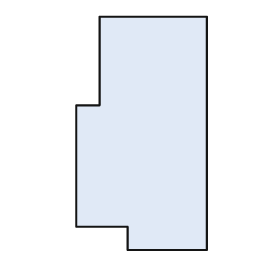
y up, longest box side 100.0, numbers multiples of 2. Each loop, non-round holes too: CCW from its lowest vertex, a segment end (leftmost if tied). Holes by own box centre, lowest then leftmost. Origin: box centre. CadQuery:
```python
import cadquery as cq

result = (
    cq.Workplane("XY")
    .moveTo(-6.0, -50.0)
    .lineTo(28.0, -50.0)
    .lineTo(28.0, 50.0)
    .lineTo(-18.0, 50.0)
    .lineTo(-18.0, 12.0)
    .lineTo(-28.0, 12.0)
    .lineTo(-28.0, -40.0)
    .lineTo(-6.0, -40.0)
    .close()
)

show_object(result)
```